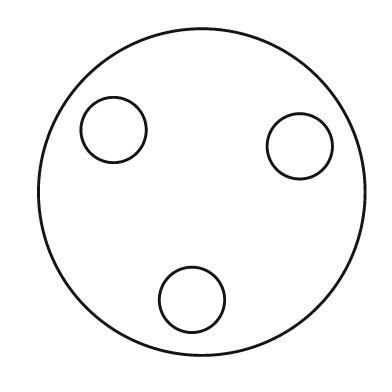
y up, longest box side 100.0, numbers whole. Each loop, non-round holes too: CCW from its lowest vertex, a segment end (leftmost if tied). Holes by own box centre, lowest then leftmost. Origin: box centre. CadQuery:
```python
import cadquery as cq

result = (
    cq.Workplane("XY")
    .moveTo(0.0, 0.0)
    .circle(50.0)
    .moveTo(-3.0, -33.0)
    .circle(10.0)
    .moveTo(30.0, 14.0)
    .circle(10.0)
    .moveTo(-27.0, 19.0)
    .circle(10.0)
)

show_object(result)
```